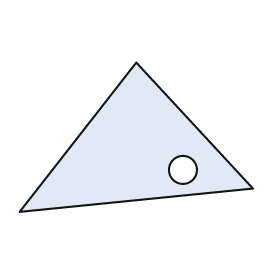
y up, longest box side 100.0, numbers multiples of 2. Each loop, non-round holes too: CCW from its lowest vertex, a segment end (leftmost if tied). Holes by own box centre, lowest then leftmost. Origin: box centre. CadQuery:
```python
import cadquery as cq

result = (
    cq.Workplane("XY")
    .moveTo(-50.0, -32.0)
    .lineTo(50.0, -22.0)
    .lineTo(0.0, 32.0)
    .close()
    .moveTo(20.0, -14.0)
    .circle(6.0)
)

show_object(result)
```